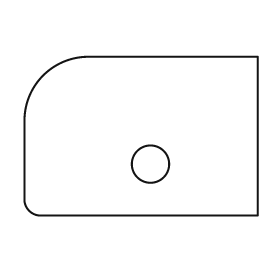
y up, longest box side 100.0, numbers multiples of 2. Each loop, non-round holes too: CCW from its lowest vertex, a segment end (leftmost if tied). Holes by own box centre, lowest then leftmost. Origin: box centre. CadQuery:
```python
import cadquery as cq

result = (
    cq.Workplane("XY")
    .moveTo(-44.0, -34.0)
    .lineTo(50.0, -34.0)
    .lineTo(50.0, 34.0)
    .lineTo(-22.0, 34.0)
    .threePointArc((-42.0, 26.0), (-50.0, 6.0))
    .lineTo(-50.0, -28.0)
    .threePointArc((-48.0, -32.0), (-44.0, -34.0))
    .close()
    .moveTo(4.0, -12.0)
    .circle(8.0)
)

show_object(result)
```